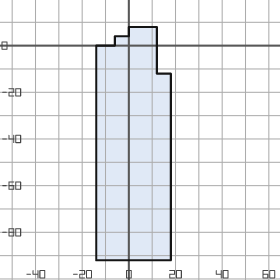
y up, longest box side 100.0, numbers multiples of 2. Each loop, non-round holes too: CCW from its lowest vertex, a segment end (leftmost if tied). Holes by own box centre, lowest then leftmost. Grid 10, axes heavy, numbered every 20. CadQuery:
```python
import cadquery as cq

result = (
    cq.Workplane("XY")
    .moveTo(-14.0, -92.0)
    .lineTo(18.0, -92.0)
    .lineTo(18.0, -12.0)
    .lineTo(12.0, -12.0)
    .lineTo(12.0, 8.0)
    .lineTo(0.0, 8.0)
    .lineTo(0.0, 4.0)
    .lineTo(-6.0, 4.0)
    .lineTo(-6.0, 0.0)
    .lineTo(-14.0, 0.0)
    .close()
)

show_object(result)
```